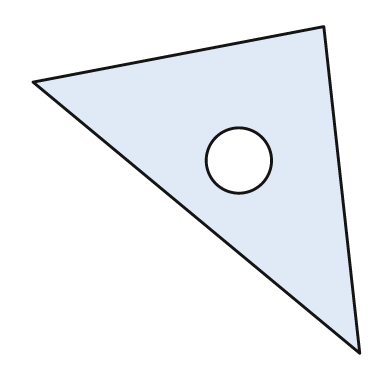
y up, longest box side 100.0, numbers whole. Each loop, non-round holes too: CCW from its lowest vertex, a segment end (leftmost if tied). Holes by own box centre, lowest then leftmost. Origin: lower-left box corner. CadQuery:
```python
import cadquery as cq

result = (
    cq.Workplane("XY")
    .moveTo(100.0, 0.0)
    .lineTo(89.0, 100.0)
    .lineTo(0.0, 83.0)
    .close()
    .moveTo(63.0, 59.0)
    .circle(10.0)
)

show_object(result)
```